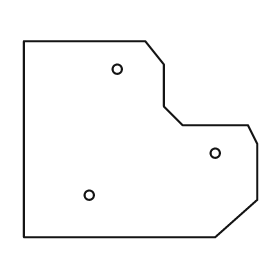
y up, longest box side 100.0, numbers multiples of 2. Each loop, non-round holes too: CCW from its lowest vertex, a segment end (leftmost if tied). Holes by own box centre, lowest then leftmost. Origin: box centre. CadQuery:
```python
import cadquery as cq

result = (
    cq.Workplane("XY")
    .moveTo(-50.0, -42.0)
    .lineTo(32.0, -42.0)
    .lineTo(50.0, -26.0)
    .lineTo(50.0, -2.0)
    .lineTo(46.0, 6.0)
    .lineTo(18.0, 6.0)
    .lineTo(10.0, 14.0)
    .lineTo(10.0, 32.0)
    .lineTo(2.0, 42.0)
    .lineTo(-50.0, 42.0)
    .close()
    .moveTo(-22.0, -24.0)
    .circle(2.0)
    .moveTo(32.0, -6.0)
    .circle(2.0)
    .moveTo(-10.0, 30.0)
    .circle(2.0)
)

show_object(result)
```